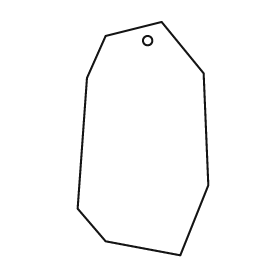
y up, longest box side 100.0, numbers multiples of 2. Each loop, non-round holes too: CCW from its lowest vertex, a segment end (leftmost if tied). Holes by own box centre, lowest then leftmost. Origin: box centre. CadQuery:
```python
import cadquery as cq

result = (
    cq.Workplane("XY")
    .moveTo(16.0, -50.0)
    .lineTo(28.0, -20.0)
    .lineTo(26.0, 28.0)
    .lineTo(8.0, 50.0)
    .lineTo(-16.0, 44.0)
    .lineTo(-24.0, 26.0)
    .lineTo(-28.0, -30.0)
    .lineTo(-16.0, -44.0)
    .close()
    .moveTo(2.0, 42.0)
    .circle(2.0)
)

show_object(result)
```